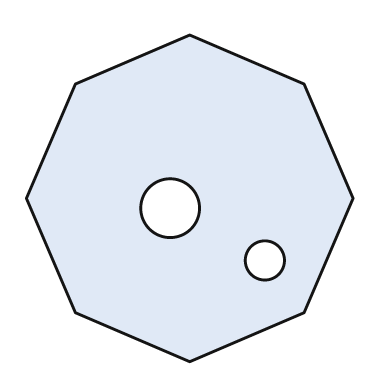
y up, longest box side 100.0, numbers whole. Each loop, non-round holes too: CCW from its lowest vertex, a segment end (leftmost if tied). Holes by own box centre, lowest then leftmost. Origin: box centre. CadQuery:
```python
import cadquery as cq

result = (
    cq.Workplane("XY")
    .moveTo(0.0, -50.0)
    .lineTo(35.0, -35.0)
    .lineTo(50.0, 0.0)
    .lineTo(35.0, 35.0)
    .lineTo(0.0, 50.0)
    .lineTo(-35.0, 35.0)
    .lineTo(-50.0, 0.0)
    .lineTo(-35.0, -35.0)
    .close()
    .moveTo(23.0, -19.0)
    .circle(6.0)
    .moveTo(-6.0, -3.0)
    .circle(9.0)
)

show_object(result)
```